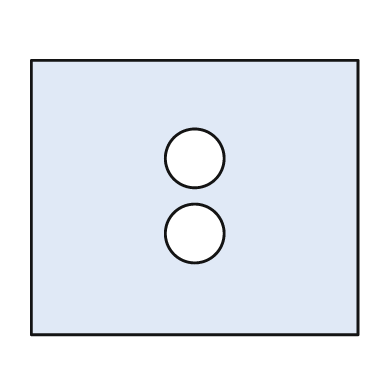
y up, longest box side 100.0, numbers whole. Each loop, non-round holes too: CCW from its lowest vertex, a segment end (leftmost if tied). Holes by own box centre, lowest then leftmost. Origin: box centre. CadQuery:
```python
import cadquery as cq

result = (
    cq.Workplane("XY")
    .moveTo(-50.0, -42.0)
    .lineTo(50.0, -42.0)
    .lineTo(50.0, 42.0)
    .lineTo(-50.0, 42.0)
    .close()
    .moveTo(0.0, -11.0)
    .circle(9.0)
    .moveTo(0.0, 12.0)
    .circle(9.0)
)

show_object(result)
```